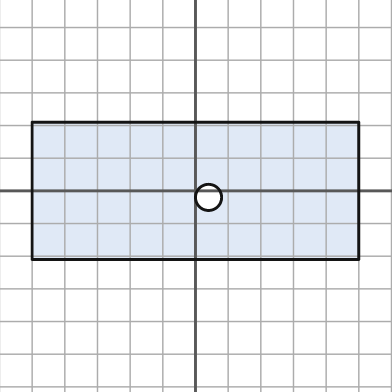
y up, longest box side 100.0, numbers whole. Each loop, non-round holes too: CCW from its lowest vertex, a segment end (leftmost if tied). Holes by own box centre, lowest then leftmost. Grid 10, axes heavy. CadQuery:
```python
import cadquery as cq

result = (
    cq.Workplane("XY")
    .moveTo(-50.0, -21.0)
    .lineTo(50.0, -21.0)
    .lineTo(50.0, 21.0)
    .lineTo(-50.0, 21.0)
    .close()
    .moveTo(4.0, -2.0)
    .circle(4.0)
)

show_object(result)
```